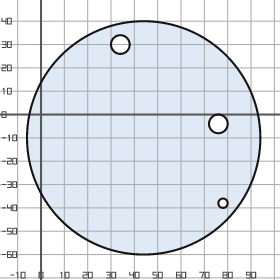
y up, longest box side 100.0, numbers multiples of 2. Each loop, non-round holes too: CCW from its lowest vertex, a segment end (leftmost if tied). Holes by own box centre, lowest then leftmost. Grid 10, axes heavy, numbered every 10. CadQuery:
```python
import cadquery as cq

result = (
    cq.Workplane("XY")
    .moveTo(44.0, -10.0)
    .circle(50.0)
    .moveTo(78.0, -38.0)
    .circle(2.0)
    .moveTo(76.0, -4.0)
    .circle(4.0)
    .moveTo(34.0, 30.0)
    .circle(4.0)
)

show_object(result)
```